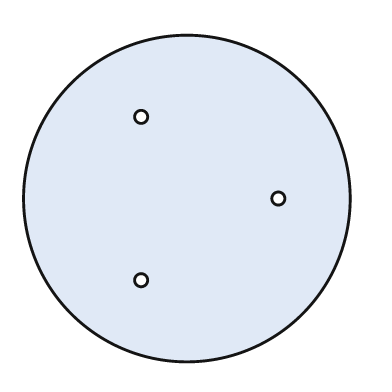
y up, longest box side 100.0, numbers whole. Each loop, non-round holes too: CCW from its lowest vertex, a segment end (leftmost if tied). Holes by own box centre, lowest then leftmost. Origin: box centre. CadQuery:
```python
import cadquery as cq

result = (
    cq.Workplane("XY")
    .moveTo(0.0, 0.0)
    .circle(50.0)
    .moveTo(-14.0, -25.0)
    .circle(2.0)
    .moveTo(28.0, 0.0)
    .circle(2.0)
    .moveTo(-14.0, 25.0)
    .circle(2.0)
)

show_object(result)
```